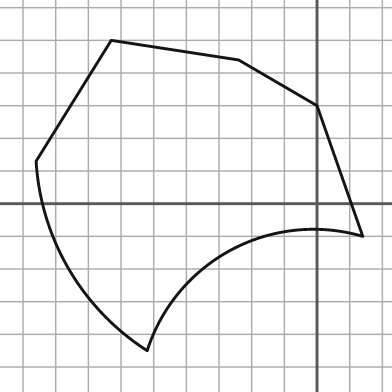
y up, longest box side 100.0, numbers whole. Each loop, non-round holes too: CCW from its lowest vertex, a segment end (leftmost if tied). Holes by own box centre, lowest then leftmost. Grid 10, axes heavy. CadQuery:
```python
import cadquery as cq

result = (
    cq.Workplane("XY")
    .moveTo(-52.0, -45.0)
    .threePointArc((-26.0, -14.0), (14.0, -10.0))
    .lineTo(0.0, 30.0)
    .lineTo(-24.0, 44.0)
    .lineTo(-63.0, 50.0)
    .lineTo(-86.0, 13.0)
    .threePointArc((-76.0, -20.0), (-52.0, -45.0))
    .close()
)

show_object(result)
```